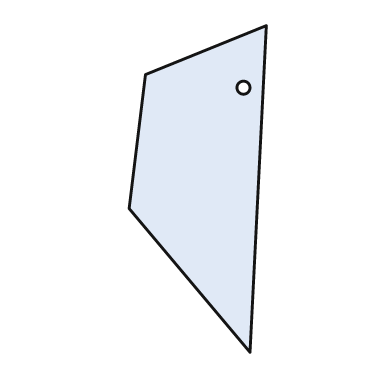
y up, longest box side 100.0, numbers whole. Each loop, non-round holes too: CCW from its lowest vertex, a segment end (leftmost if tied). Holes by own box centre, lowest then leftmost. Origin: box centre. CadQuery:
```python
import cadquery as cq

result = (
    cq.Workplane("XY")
    .moveTo(16.0, -50.0)
    .lineTo(21.0, 50.0)
    .lineTo(-16.0, 35.0)
    .lineTo(-21.0, -6.0)
    .close()
    .moveTo(14.0, 31.0)
    .circle(2.0)
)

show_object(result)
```